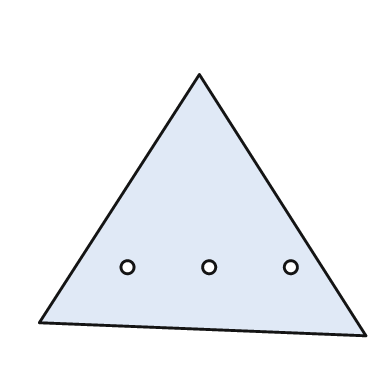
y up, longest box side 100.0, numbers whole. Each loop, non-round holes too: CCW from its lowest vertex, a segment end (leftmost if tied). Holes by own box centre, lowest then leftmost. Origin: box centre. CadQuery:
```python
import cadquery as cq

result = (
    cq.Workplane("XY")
    .moveTo(50.0, -40.0)
    .lineTo(-1.0, 40.0)
    .lineTo(-50.0, -36.0)
    .close()
    .moveTo(-23.0, -19.0)
    .circle(2.0)
    .moveTo(2.0, -19.0)
    .circle(2.0)
    .moveTo(27.0, -19.0)
    .circle(2.0)
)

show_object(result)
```